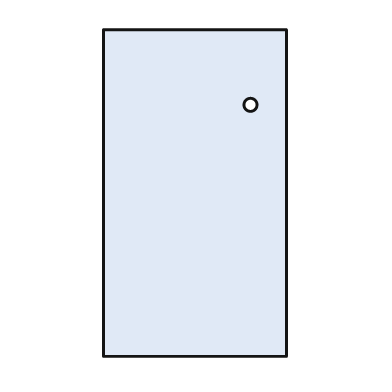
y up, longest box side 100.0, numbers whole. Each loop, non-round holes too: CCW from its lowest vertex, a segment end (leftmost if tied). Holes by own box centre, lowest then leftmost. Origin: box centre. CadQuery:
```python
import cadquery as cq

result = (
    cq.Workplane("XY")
    .moveTo(-28.0, -50.0)
    .lineTo(28.0, -50.0)
    .lineTo(28.0, 50.0)
    .lineTo(-28.0, 50.0)
    .close()
    .moveTo(17.0, 27.0)
    .circle(2.0)
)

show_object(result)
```